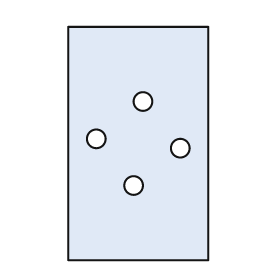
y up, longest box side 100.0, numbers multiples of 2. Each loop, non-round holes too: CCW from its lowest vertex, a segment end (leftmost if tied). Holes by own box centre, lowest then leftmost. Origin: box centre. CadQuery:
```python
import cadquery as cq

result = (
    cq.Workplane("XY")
    .moveTo(-30.0, -50.0)
    .lineTo(30.0, -50.0)
    .lineTo(30.0, 50.0)
    .lineTo(-30.0, 50.0)
    .close()
    .moveTo(-2.0, -18.0)
    .circle(4.0)
    .moveTo(18.0, -2.0)
    .circle(4.0)
    .moveTo(-18.0, 2.0)
    .circle(4.0)
    .moveTo(2.0, 18.0)
    .circle(4.0)
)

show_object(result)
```